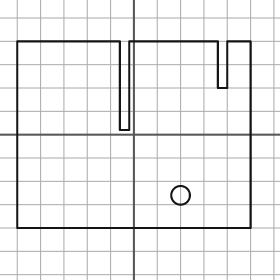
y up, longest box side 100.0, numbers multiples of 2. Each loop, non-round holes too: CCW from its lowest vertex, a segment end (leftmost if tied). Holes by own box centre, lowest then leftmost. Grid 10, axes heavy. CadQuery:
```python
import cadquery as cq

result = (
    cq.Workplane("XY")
    .moveTo(-50.0, -40.0)
    .lineTo(50.0, -40.0)
    .lineTo(50.0, 40.0)
    .lineTo(40.0, 40.0)
    .lineTo(40.0, 20.0)
    .lineTo(36.0, 20.0)
    .lineTo(36.0, 40.0)
    .lineTo(-2.0, 40.0)
    .lineTo(-2.0, 2.0)
    .lineTo(-6.0, 2.0)
    .lineTo(-6.0, 40.0)
    .lineTo(-50.0, 40.0)
    .close()
    .moveTo(20.0, -26.0)
    .circle(4.0)
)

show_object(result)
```